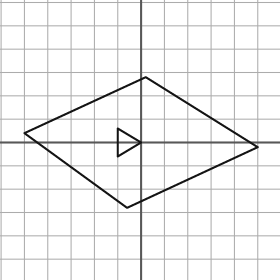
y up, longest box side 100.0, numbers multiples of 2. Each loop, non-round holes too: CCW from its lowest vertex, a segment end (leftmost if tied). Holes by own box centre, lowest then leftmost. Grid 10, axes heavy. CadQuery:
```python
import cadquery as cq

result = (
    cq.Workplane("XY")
    .moveTo(-6.0, -28.0)
    .lineTo(50.0, -2.0)
    .lineTo(2.0, 28.0)
    .lineTo(-50.0, 4.0)
    .close()
    .moveTo(-10.0, -6.0)
    .lineTo(0.0, 0.0)
    .lineTo(-10.0, 6.0)
    .close()
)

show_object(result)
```